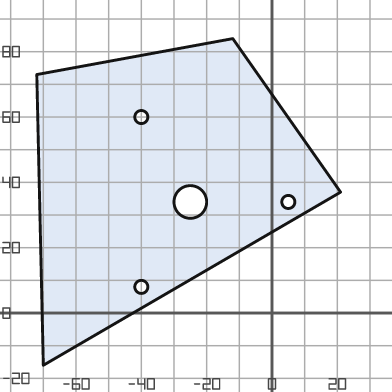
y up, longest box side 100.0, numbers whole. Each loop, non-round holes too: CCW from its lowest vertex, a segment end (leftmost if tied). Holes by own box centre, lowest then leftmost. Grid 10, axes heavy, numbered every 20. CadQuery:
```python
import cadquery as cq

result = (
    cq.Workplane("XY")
    .moveTo(-70.0, -16.0)
    .lineTo(21.0, 37.0)
    .lineTo(-12.0, 84.0)
    .lineTo(-72.0, 73.0)
    .close()
    .moveTo(-40.0, 8.0)
    .circle(2.0)
    .moveTo(-25.0, 34.0)
    .circle(5.0)
    .moveTo(5.0, 34.0)
    .circle(2.0)
    .moveTo(-40.0, 60.0)
    .circle(2.0)
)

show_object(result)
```